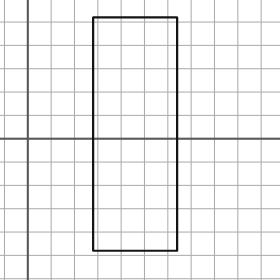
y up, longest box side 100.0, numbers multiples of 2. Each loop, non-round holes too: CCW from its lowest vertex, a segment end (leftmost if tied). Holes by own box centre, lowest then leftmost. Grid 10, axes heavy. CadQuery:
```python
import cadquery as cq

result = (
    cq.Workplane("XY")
    .moveTo(28.0, -48.0)
    .lineTo(64.0, -48.0)
    .lineTo(64.0, 52.0)
    .lineTo(28.0, 52.0)
    .close()
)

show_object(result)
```